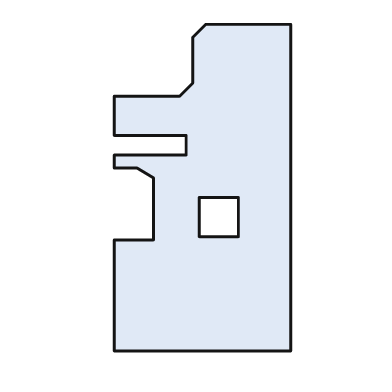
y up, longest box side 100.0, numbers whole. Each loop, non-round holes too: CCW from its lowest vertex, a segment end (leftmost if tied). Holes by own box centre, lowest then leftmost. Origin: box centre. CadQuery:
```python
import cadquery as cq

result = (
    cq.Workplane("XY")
    .moveTo(-27.0, -50.0)
    .lineTo(27.0, -50.0)
    .lineTo(27.0, 50.0)
    .lineTo(1.0, 50.0)
    .lineTo(-3.0, 46.0)
    .lineTo(-3.0, 32.0)
    .lineTo(-7.0, 28.0)
    .lineTo(-27.0, 28.0)
    .lineTo(-27.0, 16.0)
    .lineTo(-5.0, 16.0)
    .lineTo(-5.0, 10.0)
    .lineTo(-27.0, 10.0)
    .lineTo(-27.0, 6.0)
    .lineTo(-20.0, 6.0)
    .lineTo(-15.0, 3.0)
    .lineTo(-15.0, -16.0)
    .lineTo(-27.0, -16.0)
    .close()
    .moveTo(-1.0, -15.0)
    .lineTo(11.0, -15.0)
    .lineTo(11.0, -3.0)
    .lineTo(-1.0, -3.0)
    .close()
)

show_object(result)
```